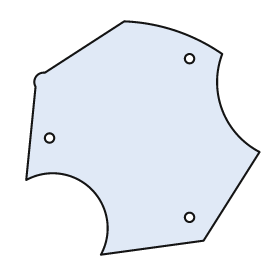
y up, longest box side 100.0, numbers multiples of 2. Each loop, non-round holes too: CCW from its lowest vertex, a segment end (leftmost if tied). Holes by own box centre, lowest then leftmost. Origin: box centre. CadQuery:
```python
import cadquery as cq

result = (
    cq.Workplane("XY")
    .moveTo(-18.0, -50.0)
    .lineTo(26.0, -44.0)
    .lineTo(50.0, -6.0)
    .threePointArc((34.0, 12.0), (34.0, 36.0))
    .threePointArc((14.0, 46.0), (-8.0, 50.0))
    .lineTo(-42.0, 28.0)
    .threePointArc((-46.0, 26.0), (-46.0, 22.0))
    .lineTo(-50.0, -18.0)
    .threePointArc((-22.0, -22.0), (-18.0, -50.0))
    .close()
    .moveTo(20.0, -34.0)
    .circle(2.0)
    .moveTo(-40.0, 0.0)
    .circle(2.0)
    .moveTo(20.0, 34.0)
    .circle(2.0)
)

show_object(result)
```